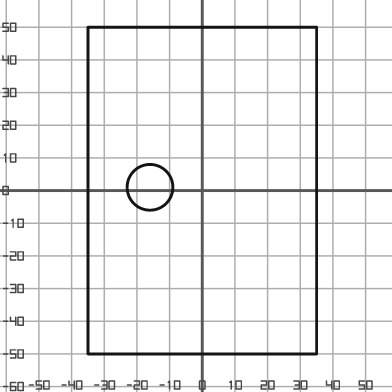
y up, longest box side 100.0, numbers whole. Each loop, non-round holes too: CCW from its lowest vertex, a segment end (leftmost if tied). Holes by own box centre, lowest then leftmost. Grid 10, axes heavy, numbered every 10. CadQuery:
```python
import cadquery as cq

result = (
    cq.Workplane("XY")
    .moveTo(-35.0, -50.0)
    .lineTo(35.0, -50.0)
    .lineTo(35.0, 50.0)
    .lineTo(-35.0, 50.0)
    .close()
    .moveTo(-16.0, 1.0)
    .circle(7.0)
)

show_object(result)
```